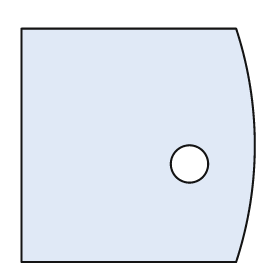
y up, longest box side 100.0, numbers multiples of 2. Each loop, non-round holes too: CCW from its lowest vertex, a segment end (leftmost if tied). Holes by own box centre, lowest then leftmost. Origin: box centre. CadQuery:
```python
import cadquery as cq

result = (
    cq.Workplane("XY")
    .moveTo(-50.0, -50.0)
    .lineTo(42.0, -50.0)
    .threePointArc((50.0, 0.0), (42.0, 50.0))
    .lineTo(-50.0, 50.0)
    .close()
    .moveTo(22.0, -8.0)
    .circle(8.0)
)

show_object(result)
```